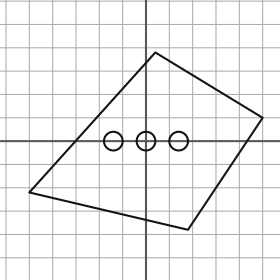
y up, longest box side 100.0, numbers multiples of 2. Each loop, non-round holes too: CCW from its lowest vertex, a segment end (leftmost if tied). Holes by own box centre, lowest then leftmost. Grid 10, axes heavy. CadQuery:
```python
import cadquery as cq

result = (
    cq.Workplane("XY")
    .moveTo(18.0, -38.0)
    .lineTo(50.0, 10.0)
    .lineTo(4.0, 38.0)
    .lineTo(-50.0, -22.0)
    .close()
    .moveTo(-14.0, 0.0)
    .circle(4.0)
    .moveTo(0.0, 0.0)
    .circle(4.0)
    .moveTo(14.0, 0.0)
    .circle(4.0)
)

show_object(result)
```